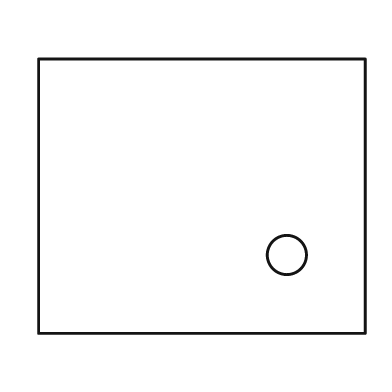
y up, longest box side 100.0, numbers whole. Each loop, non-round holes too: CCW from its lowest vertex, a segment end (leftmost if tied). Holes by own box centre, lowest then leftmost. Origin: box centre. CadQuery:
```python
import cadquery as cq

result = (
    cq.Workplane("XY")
    .moveTo(-50.0, -42.0)
    .lineTo(50.0, -42.0)
    .lineTo(50.0, 42.0)
    .lineTo(-50.0, 42.0)
    .close()
    .moveTo(26.0, -18.0)
    .circle(6.0)
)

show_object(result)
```